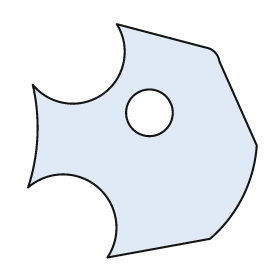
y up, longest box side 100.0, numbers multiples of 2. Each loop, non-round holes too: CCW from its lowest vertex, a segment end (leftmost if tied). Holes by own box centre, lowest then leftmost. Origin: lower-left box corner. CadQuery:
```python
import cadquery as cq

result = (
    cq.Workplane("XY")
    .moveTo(34.0, 0.0)
    .lineTo(78.0, 8.0)
    .threePointArc((92.0, 26.0), (98.0, 48.0))
    .lineTo(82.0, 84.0)
    .threePointArc((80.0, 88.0), (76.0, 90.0))
    .lineTo(38.0, 100.0)
    .threePointArc((32.0, 70.0), (2.0, 74.0))
    .threePointArc((4.0, 52.0), (0.0, 30.0))
    .threePointArc((30.0, 30.0), (34.0, 0.0))
    .close()
    .moveTo(52.0, 62.0)
    .circle(10.0)
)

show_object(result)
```